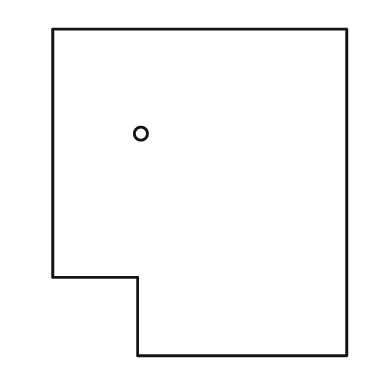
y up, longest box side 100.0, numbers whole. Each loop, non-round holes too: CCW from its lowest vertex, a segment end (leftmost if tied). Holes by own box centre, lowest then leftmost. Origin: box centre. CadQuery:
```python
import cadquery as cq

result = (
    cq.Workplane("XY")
    .moveTo(-19.0, -50.0)
    .lineTo(45.0, -50.0)
    .lineTo(45.0, 50.0)
    .lineTo(-45.0, 50.0)
    .lineTo(-45.0, -26.0)
    .lineTo(-19.0, -26.0)
    .close()
    .moveTo(-18.0, 18.0)
    .circle(2.0)
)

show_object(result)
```